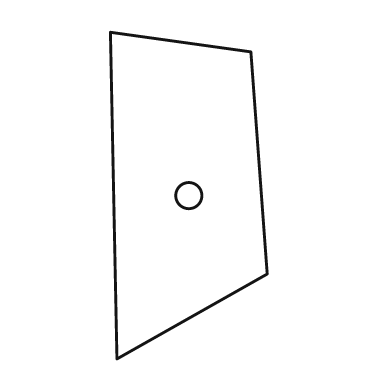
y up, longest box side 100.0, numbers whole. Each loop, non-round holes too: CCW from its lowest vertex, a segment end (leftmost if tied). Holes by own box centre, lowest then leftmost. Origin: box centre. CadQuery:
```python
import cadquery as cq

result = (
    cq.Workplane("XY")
    .moveTo(-22.0, -50.0)
    .lineTo(24.0, -24.0)
    .lineTo(19.0, 44.0)
    .lineTo(-24.0, 50.0)
    .close()
    .moveTo(0.0, 0.0)
    .circle(4.0)
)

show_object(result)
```